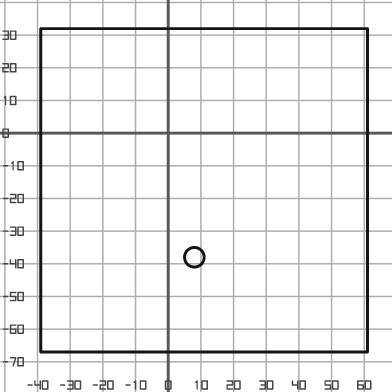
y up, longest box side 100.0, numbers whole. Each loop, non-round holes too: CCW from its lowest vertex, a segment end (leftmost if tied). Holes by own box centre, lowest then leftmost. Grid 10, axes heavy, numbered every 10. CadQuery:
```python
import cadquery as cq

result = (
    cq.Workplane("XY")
    .moveTo(-39.0, -67.0)
    .lineTo(61.0, -67.0)
    .lineTo(61.0, 32.0)
    .lineTo(-39.0, 32.0)
    .close()
    .moveTo(8.0, -38.0)
    .circle(3.0)
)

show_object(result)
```